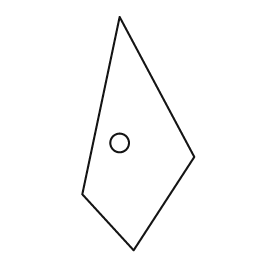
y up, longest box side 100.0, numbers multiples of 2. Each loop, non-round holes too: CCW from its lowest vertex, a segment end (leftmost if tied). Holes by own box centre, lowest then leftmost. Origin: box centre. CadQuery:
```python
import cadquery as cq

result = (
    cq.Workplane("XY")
    .moveTo(-2.0, -50.0)
    .lineTo(24.0, -10.0)
    .lineTo(-8.0, 50.0)
    .lineTo(-24.0, -26.0)
    .close()
    .moveTo(-8.0, -4.0)
    .circle(4.0)
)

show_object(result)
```